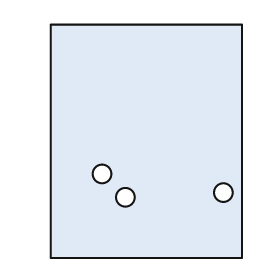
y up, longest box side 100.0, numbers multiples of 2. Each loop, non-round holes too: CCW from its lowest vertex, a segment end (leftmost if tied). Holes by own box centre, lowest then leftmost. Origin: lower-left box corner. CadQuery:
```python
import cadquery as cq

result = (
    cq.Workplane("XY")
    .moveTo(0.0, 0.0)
    .lineTo(82.0, 0.0)
    .lineTo(82.0, 100.0)
    .lineTo(0.0, 100.0)
    .close()
    .moveTo(32.0, 26.0)
    .circle(4.0)
    .moveTo(74.0, 28.0)
    .circle(4.0)
    .moveTo(22.0, 36.0)
    .circle(4.0)
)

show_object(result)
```